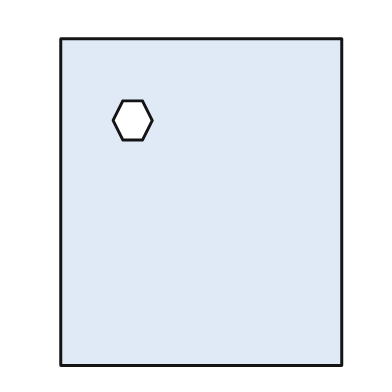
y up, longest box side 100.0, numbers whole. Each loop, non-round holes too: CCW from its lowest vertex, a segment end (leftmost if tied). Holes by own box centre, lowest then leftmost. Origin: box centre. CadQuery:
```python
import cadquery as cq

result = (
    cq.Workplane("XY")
    .moveTo(-43.0, -50.0)
    .lineTo(43.0, -50.0)
    .lineTo(43.0, 50.0)
    .lineTo(-43.0, 50.0)
    .close()
    .moveTo(-24.0, 19.0)
    .lineTo(-18.0, 19.0)
    .lineTo(-15.0, 25.0)
    .lineTo(-18.0, 31.0)
    .lineTo(-24.0, 31.0)
    .lineTo(-27.0, 25.0)
    .close()
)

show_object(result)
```